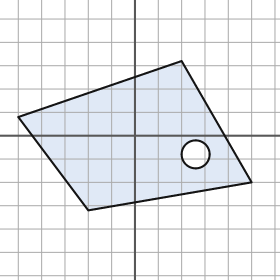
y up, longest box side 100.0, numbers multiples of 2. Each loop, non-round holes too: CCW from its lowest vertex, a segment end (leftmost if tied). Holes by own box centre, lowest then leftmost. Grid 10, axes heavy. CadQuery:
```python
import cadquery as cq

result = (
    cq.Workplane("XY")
    .moveTo(-20.0, -32.0)
    .lineTo(50.0, -20.0)
    .lineTo(20.0, 32.0)
    .lineTo(-50.0, 8.0)
    .close()
    .moveTo(26.0, -8.0)
    .circle(6.0)
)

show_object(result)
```